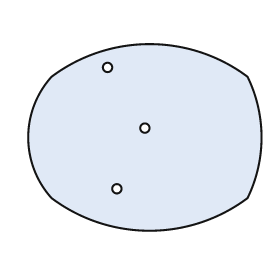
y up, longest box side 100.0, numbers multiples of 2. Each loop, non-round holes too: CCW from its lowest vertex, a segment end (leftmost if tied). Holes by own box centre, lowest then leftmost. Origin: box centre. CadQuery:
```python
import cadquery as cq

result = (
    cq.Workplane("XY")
    .moveTo(-40.0, -26.0)
    .threePointArc((2.0, -40.0), (44.0, -26.0))
    .threePointArc((50.0, 0.0), (44.0, 26.0))
    .threePointArc((2.0, 40.0), (-40.0, 26.0))
    .threePointArc((-50.0, 0.0), (-40.0, -26.0))
    .close()
    .moveTo(-12.0, -22.0)
    .circle(2.0)
    .moveTo(0.0, 4.0)
    .circle(2.0)
    .moveTo(-16.0, 30.0)
    .circle(2.0)
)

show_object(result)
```